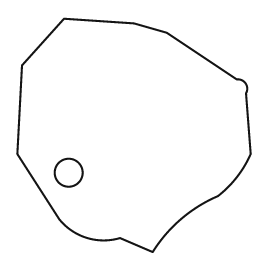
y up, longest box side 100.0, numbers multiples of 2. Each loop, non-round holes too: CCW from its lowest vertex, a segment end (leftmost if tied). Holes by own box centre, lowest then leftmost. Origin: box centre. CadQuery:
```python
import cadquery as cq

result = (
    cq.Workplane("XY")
    .moveTo(8.0, -50.0)
    .threePointArc((20.0, -36.0), (36.0, -26.0))
    .threePointArc((44.0, -18.0), (50.0, -8.0))
    .lineTo(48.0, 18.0)
    .threePointArc((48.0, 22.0), (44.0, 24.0))
    .lineTo(14.0, 44.0)
    .lineTo(0.0, 48.0)
    .lineTo(-30.0, 50.0)
    .lineTo(-48.0, 30.0)
    .lineTo(-50.0, -8.0)
    .lineTo(-32.0, -36.0)
    .threePointArc((-20.0, -44.0), (-6.0, -44.0))
    .close()
    .moveTo(-28.0, -16.0)
    .circle(6.0)
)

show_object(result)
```